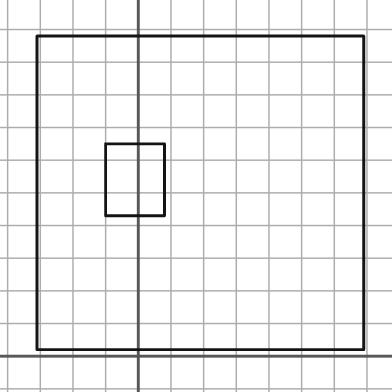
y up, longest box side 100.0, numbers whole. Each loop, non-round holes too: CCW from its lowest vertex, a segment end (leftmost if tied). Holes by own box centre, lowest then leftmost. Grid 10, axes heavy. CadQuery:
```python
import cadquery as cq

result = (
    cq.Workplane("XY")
    .moveTo(-31.0, 2.0)
    .lineTo(69.0, 2.0)
    .lineTo(69.0, 98.0)
    .lineTo(-31.0, 98.0)
    .close()
    .moveTo(-10.0, 43.0)
    .lineTo(8.0, 43.0)
    .lineTo(8.0, 65.0)
    .lineTo(-10.0, 65.0)
    .close()
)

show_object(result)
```